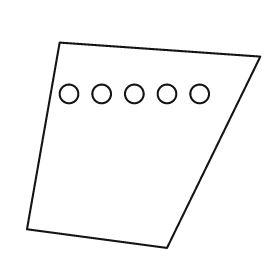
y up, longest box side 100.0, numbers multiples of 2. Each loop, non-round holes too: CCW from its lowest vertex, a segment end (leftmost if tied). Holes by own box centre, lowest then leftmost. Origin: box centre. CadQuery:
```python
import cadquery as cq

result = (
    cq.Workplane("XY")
    .moveTo(10.0, -44.0)
    .lineTo(50.0, 38.0)
    .lineTo(-36.0, 44.0)
    .lineTo(-50.0, -36.0)
    .close()
    .moveTo(-32.0, 22.0)
    .circle(4.0)
    .moveTo(-18.0, 22.0)
    .circle(4.0)
    .moveTo(-4.0, 22.0)
    .circle(4.0)
    .moveTo(10.0, 22.0)
    .circle(4.0)
    .moveTo(24.0, 22.0)
    .circle(4.0)
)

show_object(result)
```